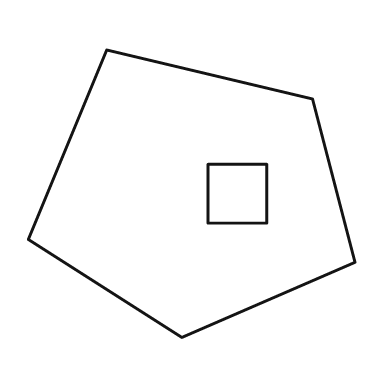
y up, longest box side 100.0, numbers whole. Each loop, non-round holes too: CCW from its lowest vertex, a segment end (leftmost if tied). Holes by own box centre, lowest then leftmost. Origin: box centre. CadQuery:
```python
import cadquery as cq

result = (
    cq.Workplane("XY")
    .moveTo(-3.0, -44.0)
    .lineTo(50.0, -21.0)
    .lineTo(37.0, 29.0)
    .lineTo(-26.0, 44.0)
    .lineTo(-50.0, -14.0)
    .close()
    .moveTo(5.0, -9.0)
    .lineTo(23.0, -9.0)
    .lineTo(23.0, 9.0)
    .lineTo(5.0, 9.0)
    .close()
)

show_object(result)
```